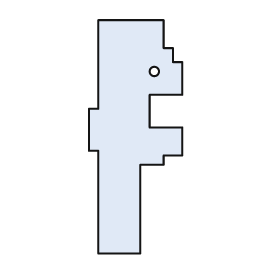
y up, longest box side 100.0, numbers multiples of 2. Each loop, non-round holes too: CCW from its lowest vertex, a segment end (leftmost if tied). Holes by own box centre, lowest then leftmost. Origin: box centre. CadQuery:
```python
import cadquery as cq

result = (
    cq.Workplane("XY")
    .moveTo(-16.0, -50.0)
    .lineTo(2.0, -50.0)
    .lineTo(2.0, -12.0)
    .lineTo(12.0, -12.0)
    .lineTo(12.0, -8.0)
    .lineTo(20.0, -8.0)
    .lineTo(20.0, 4.0)
    .lineTo(6.0, 4.0)
    .lineTo(6.0, 18.0)
    .lineTo(20.0, 18.0)
    .lineTo(20.0, 32.0)
    .lineTo(16.0, 32.0)
    .lineTo(16.0, 38.0)
    .lineTo(12.0, 38.0)
    .lineTo(12.0, 50.0)
    .lineTo(-16.0, 50.0)
    .lineTo(-16.0, 12.0)
    .lineTo(-20.0, 12.0)
    .lineTo(-20.0, -6.0)
    .lineTo(-16.0, -6.0)
    .close()
    .moveTo(8.0, 28.0)
    .circle(2.0)
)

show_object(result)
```